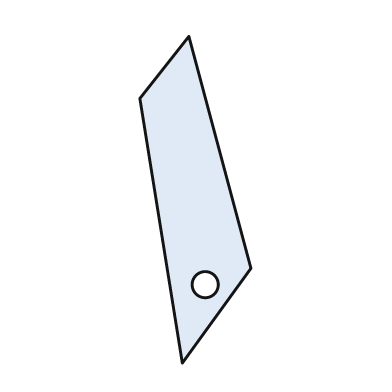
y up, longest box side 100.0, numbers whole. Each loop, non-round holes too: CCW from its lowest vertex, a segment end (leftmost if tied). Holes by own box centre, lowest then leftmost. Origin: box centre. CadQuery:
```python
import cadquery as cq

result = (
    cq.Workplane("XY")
    .moveTo(-4.0, -50.0)
    .lineTo(17.0, -21.0)
    .lineTo(-2.0, 50.0)
    .lineTo(-17.0, 31.0)
    .close()
    .moveTo(3.0, -26.0)
    .circle(4.0)
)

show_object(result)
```